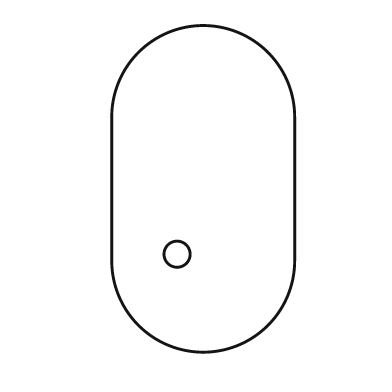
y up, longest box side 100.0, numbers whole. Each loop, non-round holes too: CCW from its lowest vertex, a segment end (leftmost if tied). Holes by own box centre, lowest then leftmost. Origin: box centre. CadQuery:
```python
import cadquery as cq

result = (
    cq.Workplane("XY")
    .moveTo(-28.0, -22.0)
    .threePointArc((0.0, -50.0), (28.0, -22.0))
    .lineTo(28.0, 22.0)
    .threePointArc((0.0, 50.0), (-28.0, 22.0))
    .close()
    .moveTo(-8.0, -20.0)
    .circle(4.0)
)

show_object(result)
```